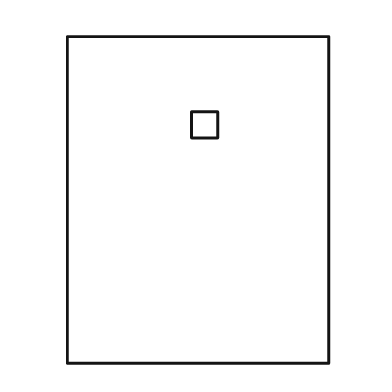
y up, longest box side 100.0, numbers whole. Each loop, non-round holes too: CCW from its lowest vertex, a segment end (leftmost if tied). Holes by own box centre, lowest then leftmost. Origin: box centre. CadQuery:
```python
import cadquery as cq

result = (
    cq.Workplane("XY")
    .moveTo(-40.0, -50.0)
    .lineTo(40.0, -50.0)
    .lineTo(40.0, 50.0)
    .lineTo(-40.0, 50.0)
    .close()
    .moveTo(-2.0, 19.0)
    .lineTo(6.0, 19.0)
    .lineTo(6.0, 27.0)
    .lineTo(-2.0, 27.0)
    .close()
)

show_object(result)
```